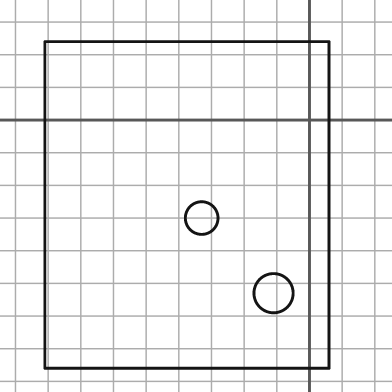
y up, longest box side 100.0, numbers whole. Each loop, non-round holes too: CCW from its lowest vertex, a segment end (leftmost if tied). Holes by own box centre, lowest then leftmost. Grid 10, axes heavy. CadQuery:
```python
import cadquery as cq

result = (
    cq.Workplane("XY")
    .moveTo(-81.0, -76.0)
    .lineTo(6.0, -76.0)
    .lineTo(6.0, 24.0)
    .lineTo(-81.0, 24.0)
    .close()
    .moveTo(-11.0, -53.0)
    .circle(6.0)
    .moveTo(-33.0, -30.0)
    .circle(5.0)
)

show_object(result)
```